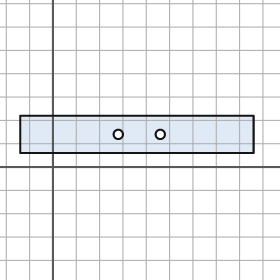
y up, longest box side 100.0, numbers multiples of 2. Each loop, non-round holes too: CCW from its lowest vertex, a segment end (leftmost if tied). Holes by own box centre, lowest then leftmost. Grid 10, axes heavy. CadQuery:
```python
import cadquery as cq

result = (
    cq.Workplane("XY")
    .moveTo(-14.0, 6.0)
    .lineTo(86.0, 6.0)
    .lineTo(86.0, 22.0)
    .lineTo(-14.0, 22.0)
    .close()
    .moveTo(28.0, 14.0)
    .circle(2.0)
    .moveTo(46.0, 14.0)
    .circle(2.0)
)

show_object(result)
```